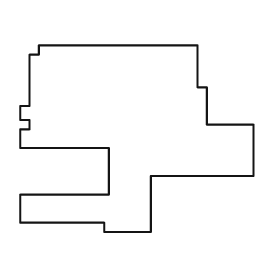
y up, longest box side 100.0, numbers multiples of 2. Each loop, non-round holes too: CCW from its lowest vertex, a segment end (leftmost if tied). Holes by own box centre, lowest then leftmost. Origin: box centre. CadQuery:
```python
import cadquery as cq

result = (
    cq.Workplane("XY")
    .moveTo(-14.0, -40.0)
    .lineTo(6.0, -40.0)
    .lineTo(6.0, -16.0)
    .lineTo(50.0, -16.0)
    .lineTo(50.0, 6.0)
    .lineTo(30.0, 6.0)
    .lineTo(30.0, 22.0)
    .lineTo(26.0, 22.0)
    .lineTo(26.0, 40.0)
    .lineTo(-42.0, 40.0)
    .lineTo(-42.0, 36.0)
    .lineTo(-46.0, 36.0)
    .lineTo(-46.0, 14.0)
    .lineTo(-50.0, 14.0)
    .lineTo(-50.0, 8.0)
    .lineTo(-46.0, 8.0)
    .lineTo(-46.0, 4.0)
    .lineTo(-50.0, 4.0)
    .lineTo(-50.0, -4.0)
    .lineTo(-12.0, -4.0)
    .lineTo(-12.0, -24.0)
    .lineTo(-50.0, -24.0)
    .lineTo(-50.0, -36.0)
    .lineTo(-14.0, -36.0)
    .close()
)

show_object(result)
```